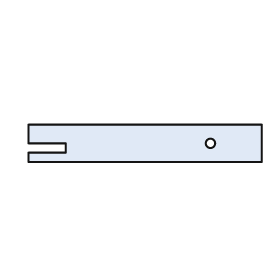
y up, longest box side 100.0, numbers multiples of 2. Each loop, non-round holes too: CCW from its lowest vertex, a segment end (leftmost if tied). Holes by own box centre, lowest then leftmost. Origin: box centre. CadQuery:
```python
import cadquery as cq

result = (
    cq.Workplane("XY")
    .moveTo(-50.0, -8.0)
    .lineTo(50.0, -8.0)
    .lineTo(50.0, 8.0)
    .lineTo(-50.0, 8.0)
    .lineTo(-50.0, 0.0)
    .lineTo(-34.0, 0.0)
    .lineTo(-34.0, -4.0)
    .lineTo(-50.0, -4.0)
    .close()
    .moveTo(28.0, 0.0)
    .circle(2.0)
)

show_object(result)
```